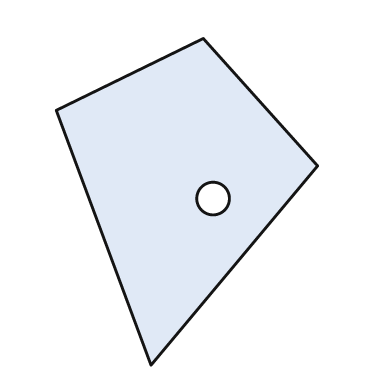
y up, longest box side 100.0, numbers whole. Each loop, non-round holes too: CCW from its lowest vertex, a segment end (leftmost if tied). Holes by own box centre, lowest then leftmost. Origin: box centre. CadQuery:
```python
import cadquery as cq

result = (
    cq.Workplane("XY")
    .moveTo(-11.0, -50.0)
    .lineTo(40.0, 11.0)
    .lineTo(5.0, 50.0)
    .lineTo(-40.0, 28.0)
    .close()
    .moveTo(8.0, 1.0)
    .circle(5.0)
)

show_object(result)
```